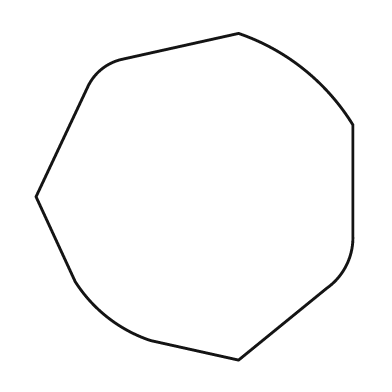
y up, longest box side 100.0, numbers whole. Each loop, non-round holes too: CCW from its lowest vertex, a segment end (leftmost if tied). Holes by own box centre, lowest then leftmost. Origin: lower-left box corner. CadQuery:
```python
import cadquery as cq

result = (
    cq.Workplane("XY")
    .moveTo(62.0, 0.0)
    .lineTo(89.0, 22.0)
    .threePointArc((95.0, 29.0), (97.0, 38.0))
    .lineTo(97.0, 72.0)
    .threePointArc((82.0, 89.0), (62.0, 100.0))
    .lineTo(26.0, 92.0)
    .threePointArc((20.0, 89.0), (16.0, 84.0))
    .lineTo(0.0, 50.0)
    .lineTo(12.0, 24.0)
    .threePointArc((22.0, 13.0), (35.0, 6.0))
    .close()
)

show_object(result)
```